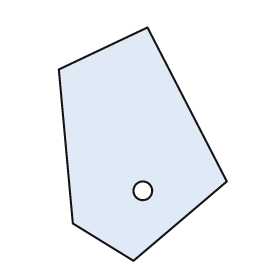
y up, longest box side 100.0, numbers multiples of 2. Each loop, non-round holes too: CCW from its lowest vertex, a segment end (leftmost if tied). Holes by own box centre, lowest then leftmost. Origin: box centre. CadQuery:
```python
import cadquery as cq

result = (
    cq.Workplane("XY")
    .moveTo(-4.0, -50.0)
    .lineTo(36.0, -16.0)
    .lineTo(2.0, 50.0)
    .lineTo(-36.0, 32.0)
    .lineTo(-30.0, -34.0)
    .close()
    .moveTo(0.0, -20.0)
    .circle(4.0)
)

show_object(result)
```